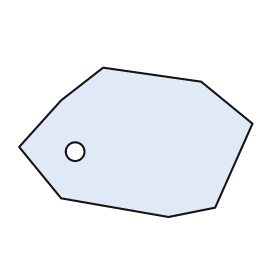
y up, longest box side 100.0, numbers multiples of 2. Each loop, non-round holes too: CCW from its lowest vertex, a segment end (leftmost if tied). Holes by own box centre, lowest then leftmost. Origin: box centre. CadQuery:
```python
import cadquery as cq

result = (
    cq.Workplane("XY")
    .moveTo(14.0, -32.0)
    .lineTo(34.0, -28.0)
    .lineTo(50.0, 8.0)
    .lineTo(28.0, 26.0)
    .lineTo(-14.0, 32.0)
    .lineTo(-32.0, 18.0)
    .lineTo(-50.0, -2.0)
    .lineTo(-32.0, -24.0)
    .close()
    .moveTo(-26.0, -4.0)
    .circle(4.0)
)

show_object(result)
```